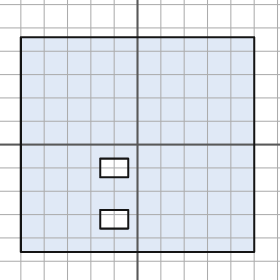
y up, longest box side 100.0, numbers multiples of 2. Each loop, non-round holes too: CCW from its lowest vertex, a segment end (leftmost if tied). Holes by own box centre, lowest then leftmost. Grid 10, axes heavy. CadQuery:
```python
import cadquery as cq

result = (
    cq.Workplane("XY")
    .moveTo(-50.0, -46.0)
    .lineTo(50.0, -46.0)
    .lineTo(50.0, 46.0)
    .lineTo(-50.0, 46.0)
    .close()
    .moveTo(-16.0, -36.0)
    .lineTo(-4.0, -36.0)
    .lineTo(-4.0, -28.0)
    .lineTo(-16.0, -28.0)
    .close()
    .moveTo(-16.0, -14.0)
    .lineTo(-4.0, -14.0)
    .lineTo(-4.0, -6.0)
    .lineTo(-16.0, -6.0)
    .close()
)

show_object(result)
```